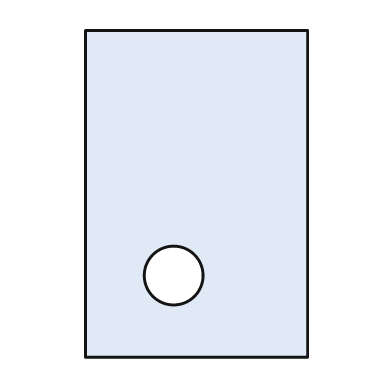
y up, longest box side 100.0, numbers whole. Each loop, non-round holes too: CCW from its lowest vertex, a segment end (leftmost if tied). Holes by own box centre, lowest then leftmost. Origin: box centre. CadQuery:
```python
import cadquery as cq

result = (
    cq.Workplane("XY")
    .moveTo(-34.0, -50.0)
    .lineTo(34.0, -50.0)
    .lineTo(34.0, 50.0)
    .lineTo(-34.0, 50.0)
    .close()
    .moveTo(-7.0, -25.0)
    .circle(9.0)
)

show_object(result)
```